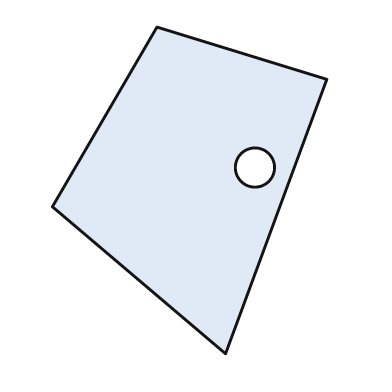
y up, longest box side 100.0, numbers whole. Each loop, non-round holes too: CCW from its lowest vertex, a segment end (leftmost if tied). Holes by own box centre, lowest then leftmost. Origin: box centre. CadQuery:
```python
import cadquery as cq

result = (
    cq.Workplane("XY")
    .moveTo(11.0, -50.0)
    .lineTo(42.0, 34.0)
    .lineTo(-10.0, 50.0)
    .lineTo(-42.0, -5.0)
    .close()
    .moveTo(20.0, 7.0)
    .circle(6.0)
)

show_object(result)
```